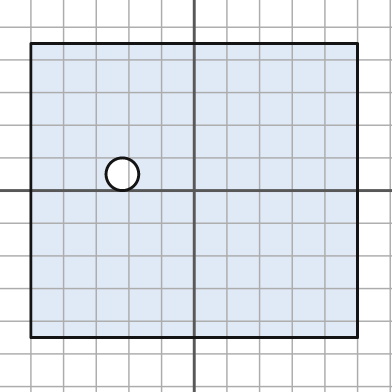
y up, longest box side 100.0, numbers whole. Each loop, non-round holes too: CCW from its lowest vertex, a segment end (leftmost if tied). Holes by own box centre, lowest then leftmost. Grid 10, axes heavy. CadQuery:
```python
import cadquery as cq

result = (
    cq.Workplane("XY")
    .moveTo(-50.0, -45.0)
    .lineTo(50.0, -45.0)
    .lineTo(50.0, 45.0)
    .lineTo(-50.0, 45.0)
    .close()
    .moveTo(-22.0, 5.0)
    .circle(5.0)
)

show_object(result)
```